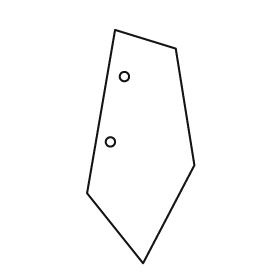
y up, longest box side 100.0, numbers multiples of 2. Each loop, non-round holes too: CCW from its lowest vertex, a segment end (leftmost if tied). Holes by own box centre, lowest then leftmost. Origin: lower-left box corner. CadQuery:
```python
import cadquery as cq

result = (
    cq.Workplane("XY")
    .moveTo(24.0, 0.0)
    .lineTo(46.0, 42.0)
    .lineTo(38.0, 92.0)
    .lineTo(12.0, 100.0)
    .lineTo(0.0, 30.0)
    .close()
    .moveTo(10.0, 52.0)
    .circle(2.0)
    .moveTo(16.0, 80.0)
    .circle(2.0)
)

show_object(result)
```